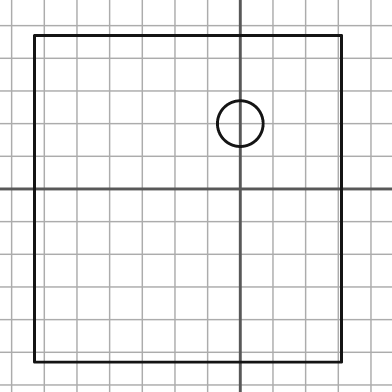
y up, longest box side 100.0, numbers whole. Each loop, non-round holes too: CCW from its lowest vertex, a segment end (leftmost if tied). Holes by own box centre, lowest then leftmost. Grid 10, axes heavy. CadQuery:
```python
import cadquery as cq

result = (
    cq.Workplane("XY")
    .moveTo(-63.0, -53.0)
    .lineTo(31.0, -53.0)
    .lineTo(31.0, 47.0)
    .lineTo(-63.0, 47.0)
    .close()
    .moveTo(0.0, 20.0)
    .circle(7.0)
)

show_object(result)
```